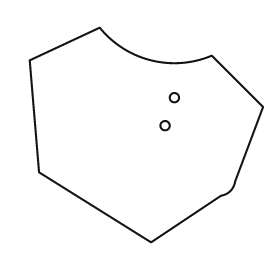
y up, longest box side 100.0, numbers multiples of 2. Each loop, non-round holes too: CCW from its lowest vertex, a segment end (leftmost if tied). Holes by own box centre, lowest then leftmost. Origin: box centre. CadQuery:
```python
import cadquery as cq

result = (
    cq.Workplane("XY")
    .moveTo(2.0, -46.0)
    .lineTo(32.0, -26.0)
    .threePointArc((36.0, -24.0), (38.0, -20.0))
    .lineTo(50.0, 12.0)
    .lineTo(28.0, 34.0)
    .threePointArc((2.0, 32.0), (-20.0, 46.0))
    .lineTo(-50.0, 32.0)
    .lineTo(-46.0, -16.0)
    .close()
    .moveTo(8.0, 4.0)
    .circle(2.0)
    .moveTo(12.0, 16.0)
    .circle(2.0)
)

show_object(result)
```